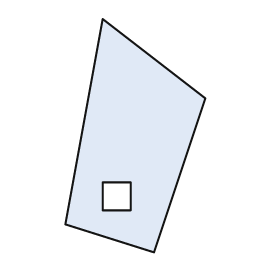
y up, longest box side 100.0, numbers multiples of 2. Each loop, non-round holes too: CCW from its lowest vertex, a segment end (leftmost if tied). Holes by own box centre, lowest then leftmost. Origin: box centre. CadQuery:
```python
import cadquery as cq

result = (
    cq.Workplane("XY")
    .moveTo(8.0, -50.0)
    .lineTo(30.0, 16.0)
    .lineTo(-14.0, 50.0)
    .lineTo(-30.0, -38.0)
    .close()
    .moveTo(-14.0, -32.0)
    .lineTo(-2.0, -32.0)
    .lineTo(-2.0, -20.0)
    .lineTo(-14.0, -20.0)
    .close()
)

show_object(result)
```